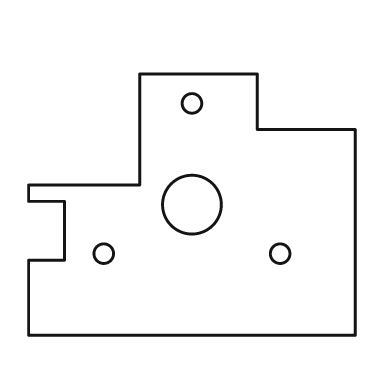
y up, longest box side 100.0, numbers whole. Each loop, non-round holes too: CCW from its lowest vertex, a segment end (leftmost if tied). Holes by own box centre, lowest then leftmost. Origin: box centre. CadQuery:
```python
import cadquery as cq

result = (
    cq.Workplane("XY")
    .moveTo(-50.0, -40.0)
    .lineTo(50.0, -40.0)
    .lineTo(50.0, 23.0)
    .lineTo(20.0, 23.0)
    .lineTo(20.0, 40.0)
    .lineTo(-16.0, 40.0)
    .lineTo(-16.0, 6.0)
    .lineTo(-50.0, 6.0)
    .lineTo(-50.0, 1.0)
    .lineTo(-39.0, 1.0)
    .lineTo(-39.0, -17.0)
    .lineTo(-50.0, -17.0)
    .close()
    .moveTo(-27.0, -15.0)
    .circle(3.0)
    .moveTo(27.0, -15.0)
    .circle(3.0)
    .moveTo(0.0, 0.0)
    .circle(9.0)
    .moveTo(0.0, 31.0)
    .circle(3.0)
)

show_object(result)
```